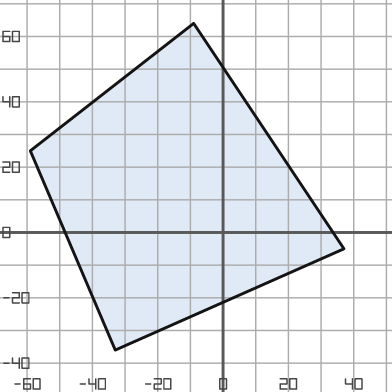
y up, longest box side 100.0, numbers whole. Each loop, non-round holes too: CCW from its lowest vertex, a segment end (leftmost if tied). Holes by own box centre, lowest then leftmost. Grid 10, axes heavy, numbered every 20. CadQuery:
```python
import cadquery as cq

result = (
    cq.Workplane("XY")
    .moveTo(-33.0, -36.0)
    .lineTo(37.0, -5.0)
    .lineTo(-9.0, 64.0)
    .lineTo(-59.0, 25.0)
    .close()
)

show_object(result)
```